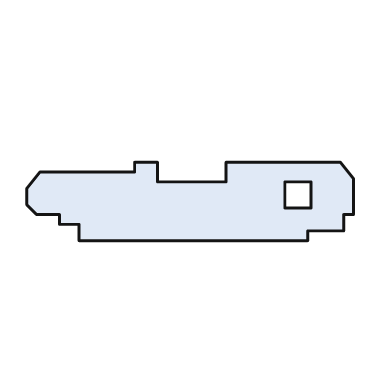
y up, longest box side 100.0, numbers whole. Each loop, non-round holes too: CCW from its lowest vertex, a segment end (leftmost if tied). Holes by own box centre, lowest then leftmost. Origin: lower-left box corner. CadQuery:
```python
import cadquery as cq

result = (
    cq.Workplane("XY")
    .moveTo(16.0, 0.0)
    .lineTo(86.0, 0.0)
    .lineTo(86.0, 3.0)
    .lineTo(97.0, 3.0)
    .lineTo(97.0, 8.0)
    .lineTo(100.0, 8.0)
    .lineTo(100.0, 19.0)
    .lineTo(96.0, 24.0)
    .lineTo(61.0, 24.0)
    .lineTo(61.0, 18.0)
    .lineTo(40.0, 18.0)
    .lineTo(40.0, 24.0)
    .lineTo(33.0, 24.0)
    .lineTo(33.0, 21.0)
    .lineTo(4.0, 21.0)
    .lineTo(0.0, 16.0)
    .lineTo(0.0, 11.0)
    .lineTo(3.0, 8.0)
    .lineTo(10.0, 8.0)
    .lineTo(10.0, 5.0)
    .lineTo(16.0, 5.0)
    .close()
    .moveTo(79.0, 10.0)
    .lineTo(87.0, 10.0)
    .lineTo(87.0, 18.0)
    .lineTo(79.0, 18.0)
    .close()
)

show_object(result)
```